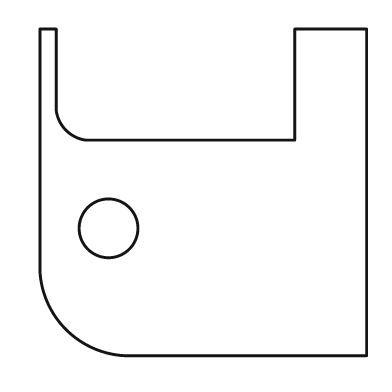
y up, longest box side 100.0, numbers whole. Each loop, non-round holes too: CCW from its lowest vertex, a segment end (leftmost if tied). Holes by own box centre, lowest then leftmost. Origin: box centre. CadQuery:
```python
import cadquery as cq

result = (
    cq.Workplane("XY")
    .moveTo(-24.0, -50.0)
    .lineTo(50.0, -50.0)
    .lineTo(50.0, 50.0)
    .lineTo(28.0, 50.0)
    .lineTo(28.0, 16.0)
    .lineTo(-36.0, 16.0)
    .threePointArc((-42.0, 19.0), (-45.0, 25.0))
    .lineTo(-45.0, 50.0)
    .lineTo(-50.0, 50.0)
    .lineTo(-50.0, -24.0)
    .threePointArc((-42.0, -42.0), (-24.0, -50.0))
    .close()
    .moveTo(-29.0, -11.0)
    .circle(9.0)
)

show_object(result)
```